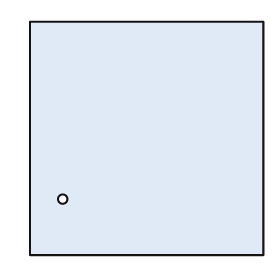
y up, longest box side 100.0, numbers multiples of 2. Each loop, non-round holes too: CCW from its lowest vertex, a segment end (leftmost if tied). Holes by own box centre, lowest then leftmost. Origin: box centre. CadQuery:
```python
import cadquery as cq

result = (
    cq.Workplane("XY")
    .moveTo(-50.0, -50.0)
    .lineTo(50.0, -50.0)
    .lineTo(50.0, 50.0)
    .lineTo(-50.0, 50.0)
    .close()
    .moveTo(-36.0, -26.0)
    .circle(2.0)
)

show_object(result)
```